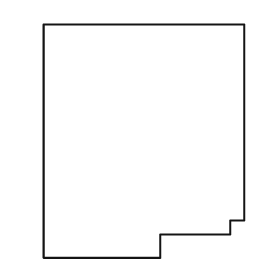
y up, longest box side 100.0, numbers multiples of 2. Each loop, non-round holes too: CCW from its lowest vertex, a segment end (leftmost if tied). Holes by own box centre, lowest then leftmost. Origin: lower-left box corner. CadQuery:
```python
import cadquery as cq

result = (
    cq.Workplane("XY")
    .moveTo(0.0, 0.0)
    .lineTo(50.0, 0.0)
    .lineTo(50.0, 10.0)
    .lineTo(80.0, 10.0)
    .lineTo(80.0, 16.0)
    .lineTo(86.0, 16.0)
    .lineTo(86.0, 100.0)
    .lineTo(0.0, 100.0)
    .close()
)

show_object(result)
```